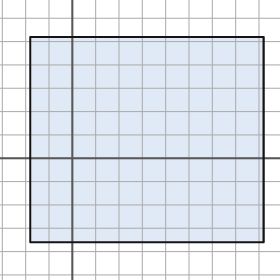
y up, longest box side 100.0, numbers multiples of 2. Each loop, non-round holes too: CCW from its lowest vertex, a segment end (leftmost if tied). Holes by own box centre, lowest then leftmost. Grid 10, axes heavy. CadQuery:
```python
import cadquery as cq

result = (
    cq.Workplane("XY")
    .moveTo(-18.0, -36.0)
    .lineTo(82.0, -36.0)
    .lineTo(82.0, 52.0)
    .lineTo(-18.0, 52.0)
    .close()
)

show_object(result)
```